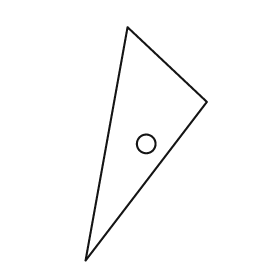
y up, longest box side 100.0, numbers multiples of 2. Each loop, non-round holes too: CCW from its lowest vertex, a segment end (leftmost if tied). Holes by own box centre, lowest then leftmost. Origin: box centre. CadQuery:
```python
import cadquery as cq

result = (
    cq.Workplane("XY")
    .moveTo(-26.0, -50.0)
    .lineTo(26.0, 18.0)
    .lineTo(-8.0, 50.0)
    .close()
    .moveTo(0.0, 0.0)
    .circle(4.0)
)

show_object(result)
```